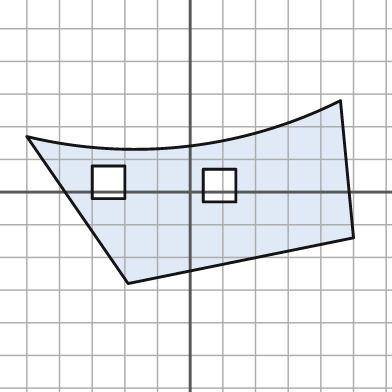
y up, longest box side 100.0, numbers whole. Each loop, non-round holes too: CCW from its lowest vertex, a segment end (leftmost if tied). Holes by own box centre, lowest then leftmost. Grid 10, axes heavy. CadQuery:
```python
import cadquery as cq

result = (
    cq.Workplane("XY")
    .moveTo(-19.0, -28.0)
    .lineTo(50.0, -14.0)
    .lineTo(46.0, 28.0)
    .threePointArc((-1.0, 14.0), (-50.0, 17.0))
    .close()
    .moveTo(4.0, -3.0)
    .lineTo(14.0, -3.0)
    .lineTo(14.0, 7.0)
    .lineTo(4.0, 7.0)
    .close()
    .moveTo(-30.0, -2.0)
    .lineTo(-20.0, -2.0)
    .lineTo(-20.0, 8.0)
    .lineTo(-30.0, 8.0)
    .close()
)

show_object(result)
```